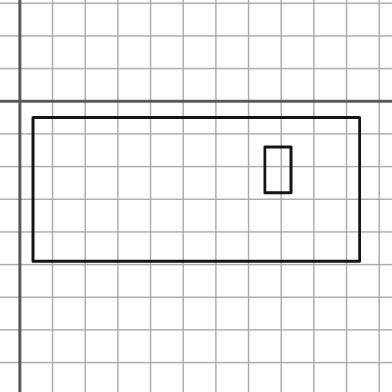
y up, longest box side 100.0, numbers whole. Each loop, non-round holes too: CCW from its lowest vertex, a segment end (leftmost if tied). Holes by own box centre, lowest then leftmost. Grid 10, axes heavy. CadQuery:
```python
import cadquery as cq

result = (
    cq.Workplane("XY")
    .moveTo(4.0, -49.0)
    .lineTo(104.0, -49.0)
    .lineTo(104.0, -5.0)
    .lineTo(4.0, -5.0)
    .close()
    .moveTo(75.0, -28.0)
    .lineTo(83.0, -28.0)
    .lineTo(83.0, -14.0)
    .lineTo(75.0, -14.0)
    .close()
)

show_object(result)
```